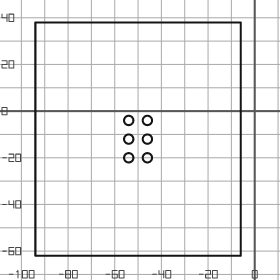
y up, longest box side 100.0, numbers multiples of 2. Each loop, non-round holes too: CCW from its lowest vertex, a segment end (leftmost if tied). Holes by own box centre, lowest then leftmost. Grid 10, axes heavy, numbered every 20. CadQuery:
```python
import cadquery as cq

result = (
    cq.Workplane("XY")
    .moveTo(-94.0, -62.0)
    .lineTo(-6.0, -62.0)
    .lineTo(-6.0, 38.0)
    .lineTo(-94.0, 38.0)
    .close()
    .moveTo(-54.0, -20.0)
    .circle(2.0)
    .moveTo(-46.0, -20.0)
    .circle(2.0)
    .moveTo(-54.0, -12.0)
    .circle(2.0)
    .moveTo(-46.0, -12.0)
    .circle(2.0)
    .moveTo(-54.0, -4.0)
    .circle(2.0)
    .moveTo(-46.0, -4.0)
    .circle(2.0)
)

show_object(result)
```